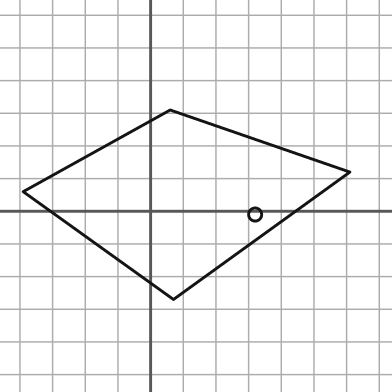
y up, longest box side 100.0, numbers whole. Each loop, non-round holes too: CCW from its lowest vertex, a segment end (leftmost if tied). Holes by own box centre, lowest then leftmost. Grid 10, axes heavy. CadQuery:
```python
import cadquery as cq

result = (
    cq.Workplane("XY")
    .moveTo(7.0, -27.0)
    .lineTo(61.0, 12.0)
    .lineTo(6.0, 31.0)
    .lineTo(-39.0, 6.0)
    .close()
    .moveTo(32.0, -1.0)
    .circle(2.0)
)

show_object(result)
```